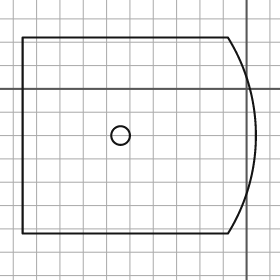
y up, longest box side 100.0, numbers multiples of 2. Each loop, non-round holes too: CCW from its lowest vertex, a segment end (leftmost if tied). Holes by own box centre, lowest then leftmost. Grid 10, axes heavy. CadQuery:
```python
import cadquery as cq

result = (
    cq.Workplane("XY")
    .moveTo(-96.0, -62.0)
    .lineTo(-8.0, -62.0)
    .threePointArc((4.0, -20.0), (-8.0, 22.0))
    .lineTo(-96.0, 22.0)
    .close()
    .moveTo(-54.0, -20.0)
    .circle(4.0)
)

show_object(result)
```